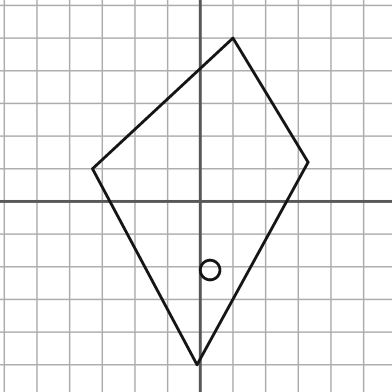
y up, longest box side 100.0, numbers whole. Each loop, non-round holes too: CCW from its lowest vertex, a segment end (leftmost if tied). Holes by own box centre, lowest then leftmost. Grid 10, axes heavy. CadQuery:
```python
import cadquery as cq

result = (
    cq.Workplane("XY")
    .moveTo(-1.0, -50.0)
    .lineTo(33.0, 12.0)
    .lineTo(10.0, 50.0)
    .lineTo(-33.0, 10.0)
    .close()
    .moveTo(3.0, -21.0)
    .circle(3.0)
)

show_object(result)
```